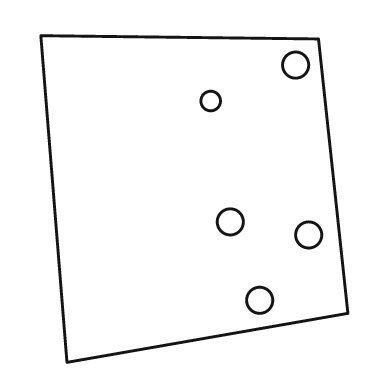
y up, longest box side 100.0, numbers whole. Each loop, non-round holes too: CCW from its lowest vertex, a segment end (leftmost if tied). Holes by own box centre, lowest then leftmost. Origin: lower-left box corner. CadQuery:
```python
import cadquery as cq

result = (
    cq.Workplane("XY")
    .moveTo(8.0, 0.0)
    .lineTo(94.0, 15.0)
    .lineTo(85.0, 99.0)
    .lineTo(0.0, 100.0)
    .close()
    .moveTo(67.0, 19.0)
    .circle(4.0)
    .moveTo(82.0, 39.0)
    .circle(4.0)
    .moveTo(58.0, 43.0)
    .circle(4.0)
    .moveTo(52.0, 80.0)
    .circle(3.0)
    .moveTo(78.0, 91.0)
    .circle(4.0)
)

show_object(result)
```